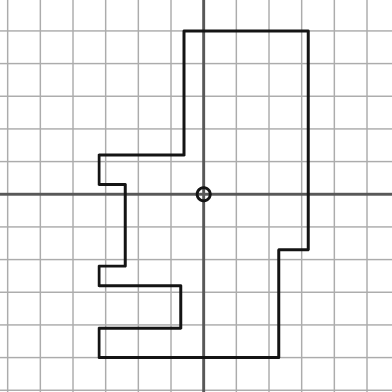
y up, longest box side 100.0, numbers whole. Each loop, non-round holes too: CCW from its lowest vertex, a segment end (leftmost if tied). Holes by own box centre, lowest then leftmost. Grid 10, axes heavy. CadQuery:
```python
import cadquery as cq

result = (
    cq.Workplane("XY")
    .moveTo(-32.0, -50.0)
    .lineTo(23.0, -50.0)
    .lineTo(23.0, -17.0)
    .lineTo(32.0, -17.0)
    .lineTo(32.0, 50.0)
    .lineTo(-6.0, 50.0)
    .lineTo(-6.0, 12.0)
    .lineTo(-32.0, 12.0)
    .lineTo(-32.0, 3.0)
    .lineTo(-24.0, 3.0)
    .lineTo(-24.0, -22.0)
    .lineTo(-32.0, -22.0)
    .lineTo(-32.0, -28.0)
    .lineTo(-7.0, -28.0)
    .lineTo(-7.0, -41.0)
    .lineTo(-32.0, -41.0)
    .close()
    .moveTo(0.0, 0.0)
    .circle(2.0)
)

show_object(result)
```